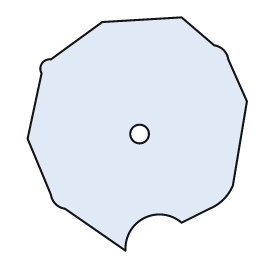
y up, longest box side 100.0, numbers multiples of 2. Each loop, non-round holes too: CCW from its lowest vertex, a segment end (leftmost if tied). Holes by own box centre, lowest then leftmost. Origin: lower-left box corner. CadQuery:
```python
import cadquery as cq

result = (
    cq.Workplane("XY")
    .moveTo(42.0, 0.0)
    .threePointArc((50.0, 14.0), (66.0, 12.0))
    .lineTo(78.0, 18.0)
    .threePointArc((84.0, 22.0), (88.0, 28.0))
    .lineTo(94.0, 64.0)
    .lineTo(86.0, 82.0)
    .threePointArc((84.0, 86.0), (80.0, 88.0))
    .lineTo(66.0, 100.0)
    .lineTo(32.0, 98.0)
    .lineTo(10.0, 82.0)
    .threePointArc((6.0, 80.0), (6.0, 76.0))
    .lineTo(0.0, 48.0)
    .lineTo(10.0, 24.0)
    .threePointArc((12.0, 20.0), (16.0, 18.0))
    .close()
    .moveTo(48.0, 50.0)
    .circle(4.0)
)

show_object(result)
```